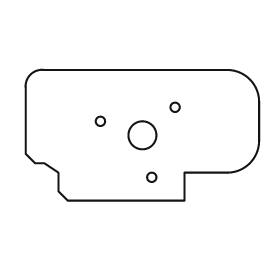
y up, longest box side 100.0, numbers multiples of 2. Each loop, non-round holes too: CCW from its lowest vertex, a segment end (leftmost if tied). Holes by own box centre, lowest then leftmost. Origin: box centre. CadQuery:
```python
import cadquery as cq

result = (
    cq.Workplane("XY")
    .moveTo(-32.0, -28.0)
    .lineTo(18.0, -28.0)
    .lineTo(18.0, -16.0)
    .lineTo(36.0, -16.0)
    .threePointArc((46.0, -12.0), (50.0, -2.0))
    .lineTo(50.0, 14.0)
    .threePointArc((46.0, 24.0), (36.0, 28.0))
    .lineTo(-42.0, 28.0)
    .threePointArc((-48.0, 26.0), (-50.0, 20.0))
    .lineTo(-50.0, -8.0)
    .lineTo(-46.0, -12.0)
    .lineTo(-42.0, -12.0)
    .lineTo(-36.0, -16.0)
    .lineTo(-36.0, -24.0)
    .close()
    .moveTo(4.0, -18.0)
    .circle(2.0)
    .moveTo(0.0, 0.0)
    .circle(6.0)
    .moveTo(-18.0, 6.0)
    .circle(2.0)
    .moveTo(14.0, 12.0)
    .circle(2.0)
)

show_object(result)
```